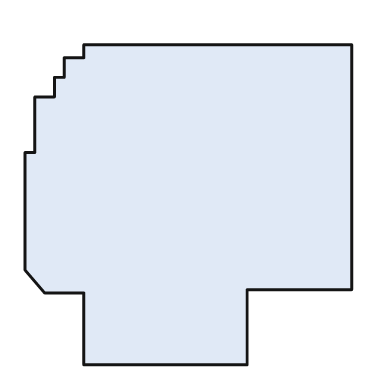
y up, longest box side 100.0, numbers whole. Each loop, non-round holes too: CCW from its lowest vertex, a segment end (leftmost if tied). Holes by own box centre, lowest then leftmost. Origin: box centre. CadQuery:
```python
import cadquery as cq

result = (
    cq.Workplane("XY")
    .moveTo(-32.0, -49.0)
    .lineTo(18.0, -49.0)
    .lineTo(18.0, -26.0)
    .lineTo(50.0, -26.0)
    .lineTo(50.0, 49.0)
    .lineTo(-32.0, 49.0)
    .lineTo(-32.0, 45.0)
    .lineTo(-38.0, 45.0)
    .lineTo(-38.0, 39.0)
    .lineTo(-41.0, 39.0)
    .lineTo(-41.0, 33.0)
    .lineTo(-47.0, 33.0)
    .lineTo(-47.0, 16.0)
    .lineTo(-50.0, 16.0)
    .lineTo(-50.0, -20.0)
    .lineTo(-44.0, -27.0)
    .lineTo(-32.0, -27.0)
    .close()
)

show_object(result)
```